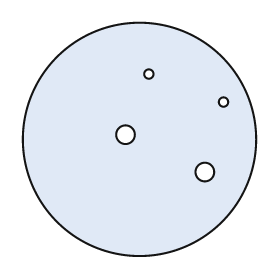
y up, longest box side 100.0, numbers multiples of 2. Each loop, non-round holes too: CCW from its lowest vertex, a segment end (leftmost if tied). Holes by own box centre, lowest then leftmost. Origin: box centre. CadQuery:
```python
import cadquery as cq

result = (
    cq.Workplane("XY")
    .moveTo(0.0, 0.0)
    .circle(50.0)
    .moveTo(28.0, -14.0)
    .circle(4.0)
    .moveTo(-6.0, 2.0)
    .circle(4.0)
    .moveTo(36.0, 16.0)
    .circle(2.0)
    .moveTo(4.0, 28.0)
    .circle(2.0)
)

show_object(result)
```